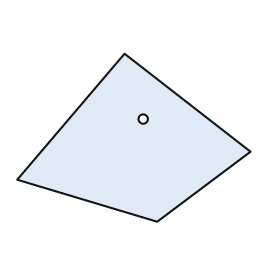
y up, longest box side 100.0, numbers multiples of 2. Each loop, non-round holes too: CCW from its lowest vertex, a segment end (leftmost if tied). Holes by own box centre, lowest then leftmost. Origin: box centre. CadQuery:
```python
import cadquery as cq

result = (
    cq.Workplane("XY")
    .moveTo(10.0, -36.0)
    .lineTo(50.0, -6.0)
    .lineTo(-4.0, 36.0)
    .lineTo(-50.0, -18.0)
    .close()
    .moveTo(4.0, 8.0)
    .circle(2.0)
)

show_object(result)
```